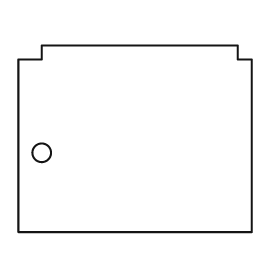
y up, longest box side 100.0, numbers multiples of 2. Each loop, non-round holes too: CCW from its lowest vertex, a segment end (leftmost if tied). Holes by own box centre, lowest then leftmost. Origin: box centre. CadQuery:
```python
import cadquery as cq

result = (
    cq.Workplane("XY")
    .moveTo(-50.0, -40.0)
    .lineTo(50.0, -40.0)
    .lineTo(50.0, 34.0)
    .lineTo(44.0, 34.0)
    .lineTo(44.0, 40.0)
    .lineTo(-40.0, 40.0)
    .lineTo(-40.0, 34.0)
    .lineTo(-50.0, 34.0)
    .close()
    .moveTo(-40.0, -6.0)
    .circle(4.0)
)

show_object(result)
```